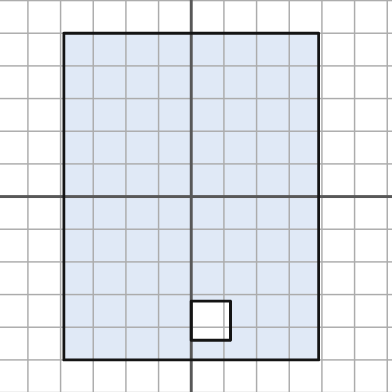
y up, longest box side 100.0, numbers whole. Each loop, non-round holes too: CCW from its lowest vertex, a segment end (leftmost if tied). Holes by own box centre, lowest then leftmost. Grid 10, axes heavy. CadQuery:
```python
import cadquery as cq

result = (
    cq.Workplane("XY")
    .moveTo(-39.0, -50.0)
    .lineTo(39.0, -50.0)
    .lineTo(39.0, 50.0)
    .lineTo(-39.0, 50.0)
    .close()
    .moveTo(0.0, -44.0)
    .lineTo(12.0, -44.0)
    .lineTo(12.0, -32.0)
    .lineTo(0.0, -32.0)
    .close()
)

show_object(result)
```